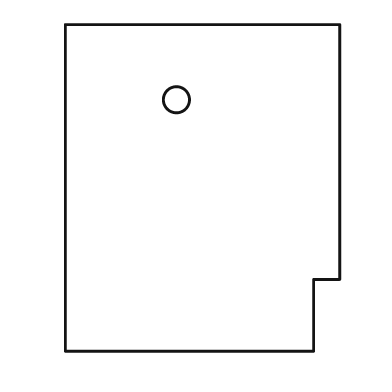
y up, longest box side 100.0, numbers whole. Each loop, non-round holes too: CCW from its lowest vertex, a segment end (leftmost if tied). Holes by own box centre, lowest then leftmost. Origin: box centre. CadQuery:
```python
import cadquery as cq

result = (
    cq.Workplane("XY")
    .moveTo(-42.0, -50.0)
    .lineTo(34.0, -50.0)
    .lineTo(34.0, -28.0)
    .lineTo(42.0, -28.0)
    .lineTo(42.0, 50.0)
    .lineTo(-42.0, 50.0)
    .close()
    .moveTo(-8.0, 27.0)
    .circle(4.0)
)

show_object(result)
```